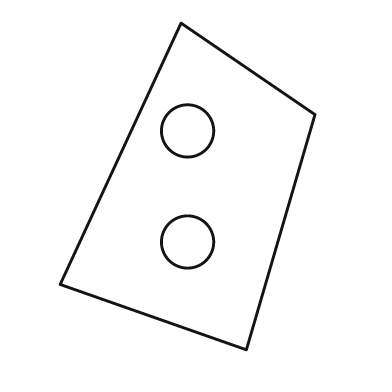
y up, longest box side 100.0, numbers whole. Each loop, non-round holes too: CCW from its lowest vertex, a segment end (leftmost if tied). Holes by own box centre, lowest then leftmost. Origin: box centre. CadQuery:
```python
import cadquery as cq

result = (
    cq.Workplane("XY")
    .moveTo(18.0, -50.0)
    .lineTo(39.0, 22.0)
    .lineTo(-2.0, 50.0)
    .lineTo(-39.0, -30.0)
    .close()
    .moveTo(0.0, -17.0)
    .circle(8.0)
    .moveTo(0.0, 17.0)
    .circle(8.0)
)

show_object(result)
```